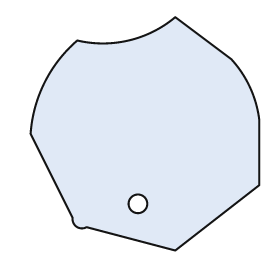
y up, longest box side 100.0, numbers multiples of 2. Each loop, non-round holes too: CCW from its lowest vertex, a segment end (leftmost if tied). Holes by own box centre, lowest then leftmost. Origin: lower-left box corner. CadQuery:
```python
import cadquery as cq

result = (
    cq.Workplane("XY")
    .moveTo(62.0, 0.0)
    .lineTo(98.0, 28.0)
    .lineTo(98.0, 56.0)
    .threePointArc((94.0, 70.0), (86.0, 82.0))
    .lineTo(62.0, 100.0)
    .threePointArc((42.0, 90.0), (20.0, 90.0))
    .threePointArc((6.0, 72.0), (0.0, 50.0))
    .lineTo(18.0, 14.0)
    .threePointArc((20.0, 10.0), (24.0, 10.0))
    .close()
    .moveTo(46.0, 20.0)
    .circle(4.0)
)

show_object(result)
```